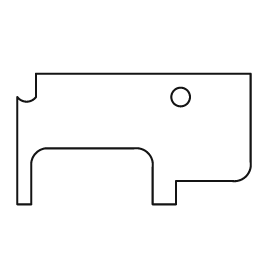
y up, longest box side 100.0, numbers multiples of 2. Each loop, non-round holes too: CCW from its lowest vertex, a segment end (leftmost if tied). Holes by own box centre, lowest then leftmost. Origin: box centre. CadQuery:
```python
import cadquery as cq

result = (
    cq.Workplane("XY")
    .moveTo(-50.0, -28.0)
    .lineTo(-44.0, -28.0)
    .lineTo(-44.0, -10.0)
    .threePointArc((-42.0, -6.0), (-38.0, -4.0))
    .lineTo(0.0, -4.0)
    .threePointArc((6.0, -6.0), (8.0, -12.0))
    .lineTo(8.0, -28.0)
    .lineTo(18.0, -28.0)
    .lineTo(18.0, -18.0)
    .lineTo(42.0, -18.0)
    .threePointArc((48.0, -16.0), (50.0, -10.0))
    .lineTo(50.0, 28.0)
    .lineTo(-42.0, 28.0)
    .lineTo(-42.0, 18.0)
    .threePointArc((-46.0, 16.0), (-50.0, 18.0))
    .close()
    .moveTo(20.0, 18.0)
    .circle(4.0)
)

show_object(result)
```